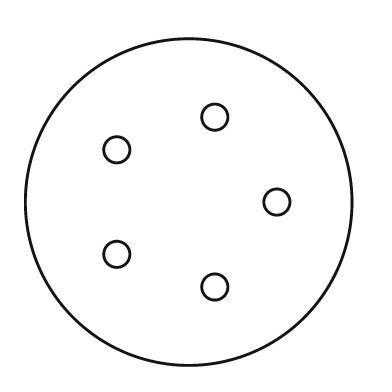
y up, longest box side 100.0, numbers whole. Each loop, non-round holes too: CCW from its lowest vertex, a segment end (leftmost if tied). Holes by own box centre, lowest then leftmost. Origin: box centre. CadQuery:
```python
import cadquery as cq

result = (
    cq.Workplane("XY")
    .moveTo(0.0, 0.0)
    .circle(50.0)
    .moveTo(8.0, -26.0)
    .circle(4.0)
    .moveTo(-22.0, -16.0)
    .circle(4.0)
    .moveTo(27.0, 0.0)
    .circle(4.0)
    .moveTo(-22.0, 16.0)
    .circle(4.0)
    .moveTo(8.0, 26.0)
    .circle(4.0)
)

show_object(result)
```